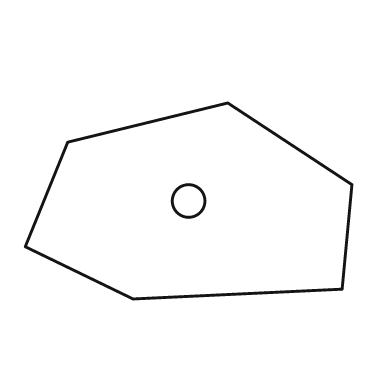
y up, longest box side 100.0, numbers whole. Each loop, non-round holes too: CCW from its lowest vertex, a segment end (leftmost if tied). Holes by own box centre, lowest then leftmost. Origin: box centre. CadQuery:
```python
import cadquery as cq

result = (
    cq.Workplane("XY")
    .moveTo(-17.0, -30.0)
    .lineTo(47.0, -27.0)
    .lineTo(50.0, 5.0)
    .lineTo(12.0, 30.0)
    .lineTo(-37.0, 18.0)
    .lineTo(-50.0, -14.0)
    .close()
    .moveTo(0.0, 0.0)
    .circle(5.0)
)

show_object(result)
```